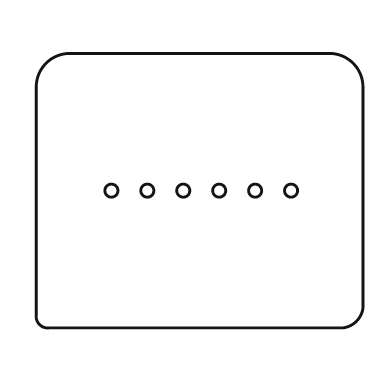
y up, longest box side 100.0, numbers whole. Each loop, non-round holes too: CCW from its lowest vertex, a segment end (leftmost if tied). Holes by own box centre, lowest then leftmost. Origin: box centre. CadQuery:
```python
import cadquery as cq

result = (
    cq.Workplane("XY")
    .moveTo(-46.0, -42.0)
    .lineTo(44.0, -42.0)
    .threePointArc((48.0, -40.0), (50.0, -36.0))
    .lineTo(50.0, 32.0)
    .threePointArc((47.0, 39.0), (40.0, 42.0))
    .lineTo(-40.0, 42.0)
    .threePointArc((-47.0, 39.0), (-50.0, 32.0))
    .lineTo(-50.0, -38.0)
    .threePointArc((-49.0, -41.0), (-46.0, -42.0))
    .close()
    .moveTo(-27.0, 0.0)
    .circle(2.0)
    .moveTo(-16.0, 0.0)
    .circle(2.0)
    .moveTo(-5.0, 0.0)
    .circle(2.0)
    .moveTo(6.0, 0.0)
    .circle(2.0)
    .moveTo(17.0, 0.0)
    .circle(2.0)
    .moveTo(28.0, 0.0)
    .circle(2.0)
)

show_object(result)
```